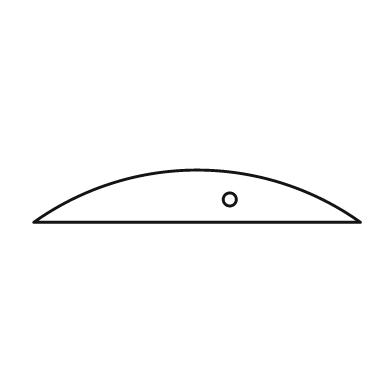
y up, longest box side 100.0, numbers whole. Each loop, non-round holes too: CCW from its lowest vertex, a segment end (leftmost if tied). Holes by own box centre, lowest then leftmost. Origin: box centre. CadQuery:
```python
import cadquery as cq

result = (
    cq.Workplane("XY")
    .moveTo(-50.0, -8.0)
    .lineTo(50.0, -8.0)
    .threePointArc((0.0, 8.0), (-50.0, -8.0))
    .close()
    .moveTo(10.0, -1.0)
    .circle(2.0)
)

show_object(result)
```